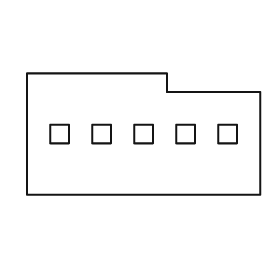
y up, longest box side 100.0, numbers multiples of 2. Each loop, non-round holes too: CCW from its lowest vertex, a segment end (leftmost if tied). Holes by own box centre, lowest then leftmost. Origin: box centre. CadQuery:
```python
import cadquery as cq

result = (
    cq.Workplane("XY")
    .moveTo(-50.0, -26.0)
    .lineTo(50.0, -26.0)
    .lineTo(50.0, 18.0)
    .lineTo(10.0, 18.0)
    .lineTo(10.0, 26.0)
    .lineTo(-50.0, 26.0)
    .close()
    .moveTo(-40.0, -4.0)
    .lineTo(-32.0, -4.0)
    .lineTo(-32.0, 4.0)
    .lineTo(-40.0, 4.0)
    .close()
    .moveTo(-22.0, -4.0)
    .lineTo(-14.0, -4.0)
    .lineTo(-14.0, 4.0)
    .lineTo(-22.0, 4.0)
    .close()
    .moveTo(-4.0, -4.0)
    .lineTo(4.0, -4.0)
    .lineTo(4.0, 4.0)
    .lineTo(-4.0, 4.0)
    .close()
    .moveTo(14.0, -4.0)
    .lineTo(22.0, -4.0)
    .lineTo(22.0, 4.0)
    .lineTo(14.0, 4.0)
    .close()
    .moveTo(32.0, -4.0)
    .lineTo(40.0, -4.0)
    .lineTo(40.0, 4.0)
    .lineTo(32.0, 4.0)
    .close()
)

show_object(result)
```